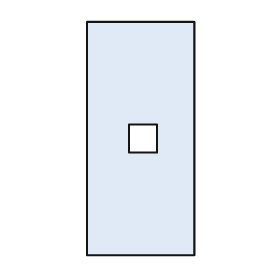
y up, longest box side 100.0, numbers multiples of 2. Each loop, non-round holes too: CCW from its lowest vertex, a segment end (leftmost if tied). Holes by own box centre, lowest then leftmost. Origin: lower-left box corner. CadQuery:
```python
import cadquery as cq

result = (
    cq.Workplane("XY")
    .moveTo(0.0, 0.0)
    .lineTo(46.0, 0.0)
    .lineTo(46.0, 100.0)
    .lineTo(0.0, 100.0)
    .close()
    .moveTo(18.0, 44.0)
    .lineTo(30.0, 44.0)
    .lineTo(30.0, 56.0)
    .lineTo(18.0, 56.0)
    .close()
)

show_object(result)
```